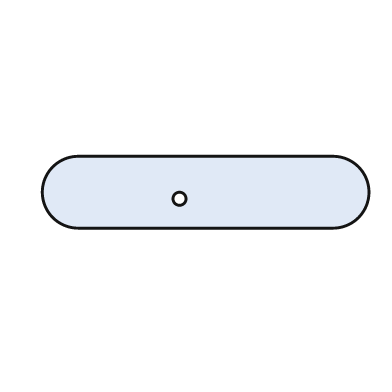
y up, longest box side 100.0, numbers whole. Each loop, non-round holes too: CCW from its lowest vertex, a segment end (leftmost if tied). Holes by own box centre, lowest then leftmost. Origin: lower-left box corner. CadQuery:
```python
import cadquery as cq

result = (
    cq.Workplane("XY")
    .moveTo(11.0, 0.0)
    .lineTo(89.0, 0.0)
    .threePointArc((100.0, 11.0), (89.0, 22.0))
    .lineTo(11.0, 22.0)
    .threePointArc((0.0, 11.0), (11.0, 0.0))
    .close()
    .moveTo(42.0, 9.0)
    .circle(2.0)
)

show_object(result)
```